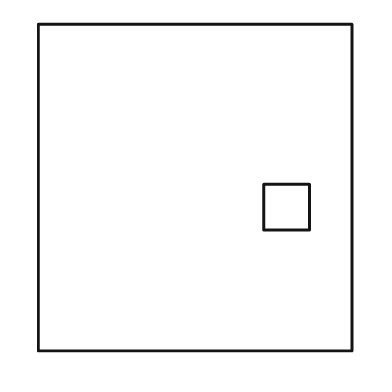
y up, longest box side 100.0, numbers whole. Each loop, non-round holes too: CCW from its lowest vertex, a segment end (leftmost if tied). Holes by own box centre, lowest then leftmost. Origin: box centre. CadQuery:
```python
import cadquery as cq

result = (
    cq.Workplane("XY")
    .moveTo(-48.0, -50.0)
    .lineTo(48.0, -50.0)
    .lineTo(48.0, 50.0)
    .lineTo(-48.0, 50.0)
    .close()
    .moveTo(21.0, -13.0)
    .lineTo(35.0, -13.0)
    .lineTo(35.0, 1.0)
    .lineTo(21.0, 1.0)
    .close()
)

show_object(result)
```